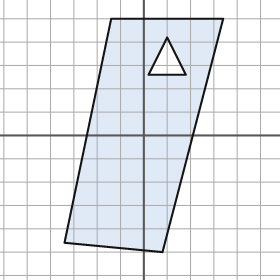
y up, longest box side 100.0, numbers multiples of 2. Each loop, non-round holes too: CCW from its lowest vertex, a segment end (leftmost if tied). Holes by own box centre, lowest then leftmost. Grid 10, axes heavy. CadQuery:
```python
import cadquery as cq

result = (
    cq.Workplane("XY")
    .moveTo(8.0, -50.0)
    .lineTo(34.0, 50.0)
    .lineTo(-14.0, 50.0)
    .lineTo(-34.0, -46.0)
    .close()
    .moveTo(2.0, 26.0)
    .lineTo(18.0, 26.0)
    .lineTo(10.0, 42.0)
    .close()
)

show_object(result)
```